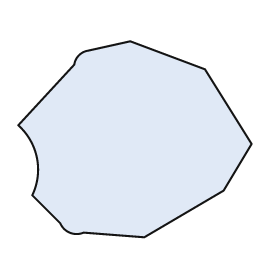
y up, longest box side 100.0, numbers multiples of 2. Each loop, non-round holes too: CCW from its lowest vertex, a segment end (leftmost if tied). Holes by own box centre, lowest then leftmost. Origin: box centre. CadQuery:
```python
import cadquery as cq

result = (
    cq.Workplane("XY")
    .moveTo(4.0, -42.0)
    .lineTo(38.0, -22.0)
    .lineTo(50.0, -2.0)
    .lineTo(30.0, 30.0)
    .lineTo(-2.0, 42.0)
    .lineTo(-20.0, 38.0)
    .threePointArc((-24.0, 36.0), (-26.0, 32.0))
    .lineTo(-50.0, 6.0)
    .threePointArc((-42.0, -8.0), (-44.0, -24.0))
    .lineTo(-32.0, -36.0)
    .threePointArc((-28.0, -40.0), (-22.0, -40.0))
    .close()
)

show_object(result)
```